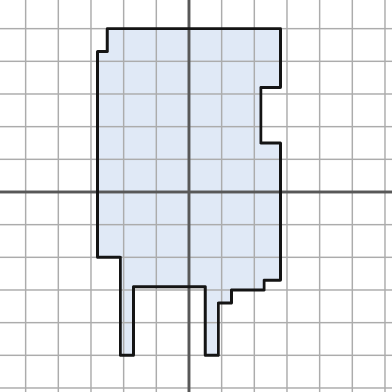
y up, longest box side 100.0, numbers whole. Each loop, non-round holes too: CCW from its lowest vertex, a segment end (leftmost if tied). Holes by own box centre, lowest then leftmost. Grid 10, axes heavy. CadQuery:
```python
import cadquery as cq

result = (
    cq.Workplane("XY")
    .moveTo(-21.0, -50.0)
    .lineTo(-17.0, -50.0)
    .lineTo(-17.0, -29.0)
    .lineTo(5.0, -29.0)
    .lineTo(5.0, -50.0)
    .lineTo(9.0, -50.0)
    .lineTo(9.0, -34.0)
    .lineTo(13.0, -34.0)
    .lineTo(13.0, -30.0)
    .lineTo(23.0, -30.0)
    .lineTo(23.0, -27.0)
    .lineTo(28.0, -27.0)
    .lineTo(28.0, 15.0)
    .lineTo(22.0, 15.0)
    .lineTo(22.0, 32.0)
    .lineTo(28.0, 32.0)
    .lineTo(28.0, 50.0)
    .lineTo(-25.0, 50.0)
    .lineTo(-25.0, 43.0)
    .lineTo(-28.0, 43.0)
    .lineTo(-28.0, -20.0)
    .lineTo(-21.0, -20.0)
    .close()
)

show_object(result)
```